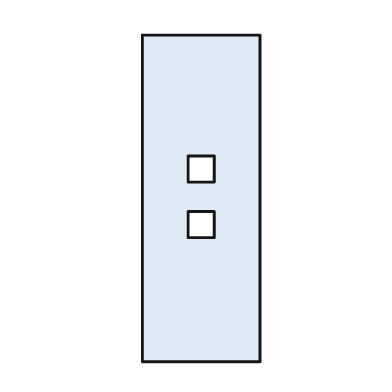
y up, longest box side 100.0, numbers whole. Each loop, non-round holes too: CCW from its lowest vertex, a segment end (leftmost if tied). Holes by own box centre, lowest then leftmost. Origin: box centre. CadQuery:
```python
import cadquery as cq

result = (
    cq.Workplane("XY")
    .moveTo(-18.0, -50.0)
    .lineTo(18.0, -50.0)
    .lineTo(18.0, 50.0)
    .lineTo(-18.0, 50.0)
    .close()
    .moveTo(-4.0, -12.0)
    .lineTo(4.0, -12.0)
    .lineTo(4.0, -4.0)
    .lineTo(-4.0, -4.0)
    .close()
    .moveTo(-4.0, 5.0)
    .lineTo(4.0, 5.0)
    .lineTo(4.0, 13.0)
    .lineTo(-4.0, 13.0)
    .close()
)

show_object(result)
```